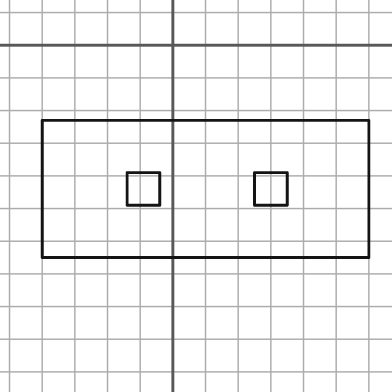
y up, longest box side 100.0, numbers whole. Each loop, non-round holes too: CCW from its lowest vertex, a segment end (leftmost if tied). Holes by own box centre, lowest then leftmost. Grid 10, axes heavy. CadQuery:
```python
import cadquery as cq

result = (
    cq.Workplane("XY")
    .moveTo(-40.0, -65.0)
    .lineTo(60.0, -65.0)
    .lineTo(60.0, -23.0)
    .lineTo(-40.0, -23.0)
    .close()
    .moveTo(-14.0, -49.0)
    .lineTo(-4.0, -49.0)
    .lineTo(-4.0, -39.0)
    .lineTo(-14.0, -39.0)
    .close()
    .moveTo(25.0, -49.0)
    .lineTo(35.0, -49.0)
    .lineTo(35.0, -39.0)
    .lineTo(25.0, -39.0)
    .close()
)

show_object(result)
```